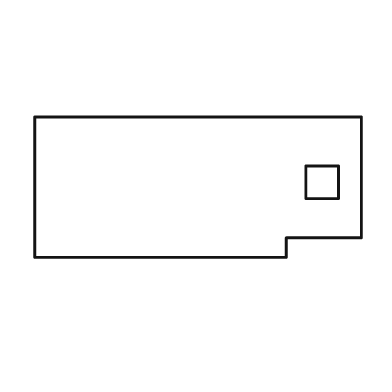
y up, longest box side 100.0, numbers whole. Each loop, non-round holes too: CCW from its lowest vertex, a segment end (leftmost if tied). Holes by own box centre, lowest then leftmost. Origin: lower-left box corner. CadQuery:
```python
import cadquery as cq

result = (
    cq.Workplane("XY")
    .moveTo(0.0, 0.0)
    .lineTo(77.0, 0.0)
    .lineTo(77.0, 6.0)
    .lineTo(100.0, 6.0)
    .lineTo(100.0, 43.0)
    .lineTo(0.0, 43.0)
    .close()
    .moveTo(83.0, 18.0)
    .lineTo(93.0, 18.0)
    .lineTo(93.0, 28.0)
    .lineTo(83.0, 28.0)
    .close()
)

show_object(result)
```